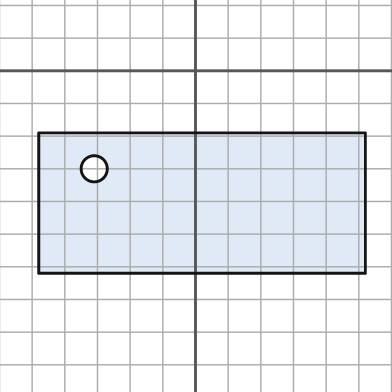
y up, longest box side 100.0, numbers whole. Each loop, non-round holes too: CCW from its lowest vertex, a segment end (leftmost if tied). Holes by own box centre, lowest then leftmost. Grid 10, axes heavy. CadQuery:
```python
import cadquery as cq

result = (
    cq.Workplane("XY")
    .moveTo(-48.0, -62.0)
    .lineTo(52.0, -62.0)
    .lineTo(52.0, -19.0)
    .lineTo(-48.0, -19.0)
    .close()
    .moveTo(-31.0, -30.0)
    .circle(4.0)
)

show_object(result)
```